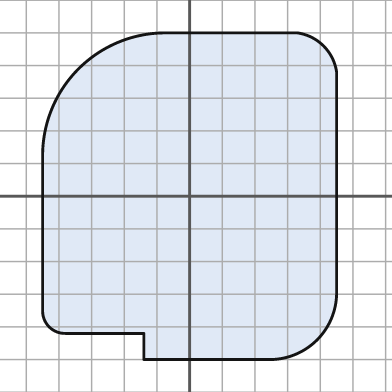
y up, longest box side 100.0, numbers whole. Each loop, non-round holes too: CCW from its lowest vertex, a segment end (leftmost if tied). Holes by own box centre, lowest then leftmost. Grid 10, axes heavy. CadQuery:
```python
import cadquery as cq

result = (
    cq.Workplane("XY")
    .moveTo(-14.0, -50.0)
    .lineTo(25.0, -50.0)
    .threePointArc((39.0, -44.0), (45.0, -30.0))
    .lineTo(45.0, 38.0)
    .threePointArc((41.0, 46.0), (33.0, 50.0))
    .lineTo(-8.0, 50.0)
    .threePointArc((-34.0, 39.0), (-45.0, 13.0))
    .lineTo(-45.0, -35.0)
    .threePointArc((-43.0, -40.0), (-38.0, -42.0))
    .lineTo(-14.0, -42.0)
    .close()
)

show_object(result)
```